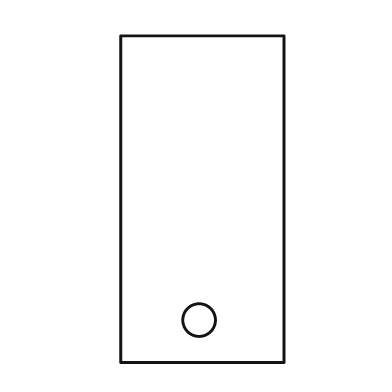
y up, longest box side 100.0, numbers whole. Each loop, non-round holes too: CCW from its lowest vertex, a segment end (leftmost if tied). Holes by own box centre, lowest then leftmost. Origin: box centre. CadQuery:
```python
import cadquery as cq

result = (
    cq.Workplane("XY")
    .moveTo(-25.0, -50.0)
    .lineTo(25.0, -50.0)
    .lineTo(25.0, 50.0)
    .lineTo(-25.0, 50.0)
    .close()
    .moveTo(-1.0, -37.0)
    .circle(5.0)
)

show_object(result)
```